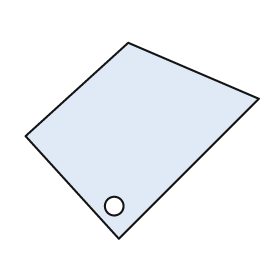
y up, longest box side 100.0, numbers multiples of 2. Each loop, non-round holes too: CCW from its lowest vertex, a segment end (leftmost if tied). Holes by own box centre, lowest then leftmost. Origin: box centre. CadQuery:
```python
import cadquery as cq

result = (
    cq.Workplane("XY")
    .moveTo(-10.0, -42.0)
    .lineTo(50.0, 18.0)
    .lineTo(-6.0, 42.0)
    .lineTo(-50.0, 2.0)
    .close()
    .moveTo(-12.0, -28.0)
    .circle(4.0)
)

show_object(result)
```